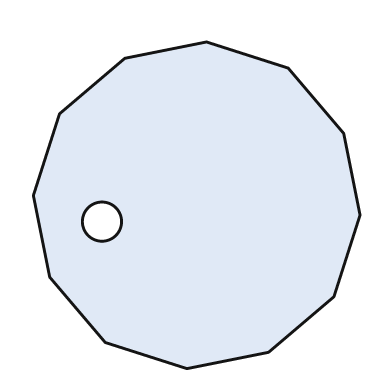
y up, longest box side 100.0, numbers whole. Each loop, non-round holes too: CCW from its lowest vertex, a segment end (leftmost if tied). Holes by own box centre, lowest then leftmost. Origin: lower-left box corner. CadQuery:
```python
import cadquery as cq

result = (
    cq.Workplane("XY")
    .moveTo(47.0, 0.0)
    .lineTo(72.0, 5.0)
    .lineTo(92.0, 22.0)
    .lineTo(100.0, 47.0)
    .lineTo(95.0, 72.0)
    .lineTo(78.0, 92.0)
    .lineTo(53.0, 100.0)
    .lineTo(28.0, 95.0)
    .lineTo(8.0, 78.0)
    .lineTo(0.0, 53.0)
    .lineTo(5.0, 28.0)
    .lineTo(22.0, 8.0)
    .close()
    .moveTo(21.0, 45.0)
    .circle(6.0)
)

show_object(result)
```